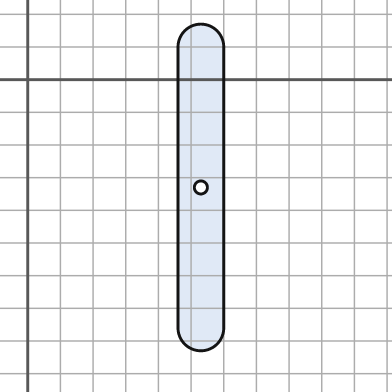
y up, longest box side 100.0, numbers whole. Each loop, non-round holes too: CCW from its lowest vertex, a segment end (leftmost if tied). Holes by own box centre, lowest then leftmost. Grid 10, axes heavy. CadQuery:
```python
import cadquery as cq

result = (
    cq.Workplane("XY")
    .moveTo(46.0, -76.0)
    .threePointArc((53.0, -83.0), (60.0, -76.0))
    .lineTo(60.0, 10.0)
    .threePointArc((53.0, 17.0), (46.0, 10.0))
    .close()
    .moveTo(53.0, -33.0)
    .circle(2.0)
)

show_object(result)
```